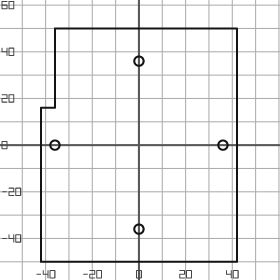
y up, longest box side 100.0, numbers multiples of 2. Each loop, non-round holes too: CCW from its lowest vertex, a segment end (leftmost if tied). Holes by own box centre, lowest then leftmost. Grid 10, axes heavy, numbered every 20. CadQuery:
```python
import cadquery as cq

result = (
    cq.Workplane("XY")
    .moveTo(-42.0, -50.0)
    .lineTo(42.0, -50.0)
    .lineTo(42.0, 50.0)
    .lineTo(-36.0, 50.0)
    .lineTo(-36.0, 16.0)
    .lineTo(-42.0, 16.0)
    .close()
    .moveTo(0.0, -36.0)
    .circle(2.0)
    .moveTo(-36.0, 0.0)
    .circle(2.0)
    .moveTo(36.0, 0.0)
    .circle(2.0)
    .moveTo(0.0, 36.0)
    .circle(2.0)
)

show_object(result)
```